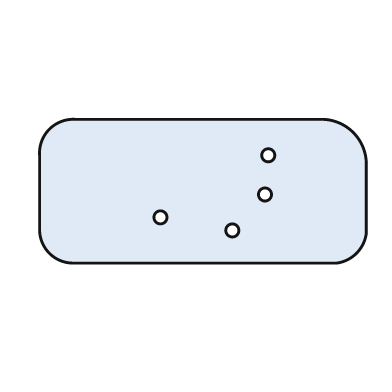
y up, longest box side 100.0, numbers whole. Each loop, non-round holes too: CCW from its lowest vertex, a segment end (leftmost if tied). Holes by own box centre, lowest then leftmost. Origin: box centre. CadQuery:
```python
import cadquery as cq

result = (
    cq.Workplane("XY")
    .moveTo(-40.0, -22.0)
    .lineTo(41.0, -22.0)
    .threePointArc((47.0, -19.0), (50.0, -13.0))
    .lineTo(50.0, 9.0)
    .threePointArc((46.0, 18.0), (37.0, 22.0))
    .lineTo(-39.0, 22.0)
    .threePointArc((-47.0, 19.0), (-50.0, 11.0))
    .lineTo(-50.0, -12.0)
    .threePointArc((-47.0, -19.0), (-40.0, -22.0))
    .close()
    .moveTo(9.0, -12.0)
    .circle(2.0)
    .moveTo(-13.0, -8.0)
    .circle(2.0)
    .moveTo(19.0, -1.0)
    .circle(2.0)
    .moveTo(20.0, 11.0)
    .circle(2.0)
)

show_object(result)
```